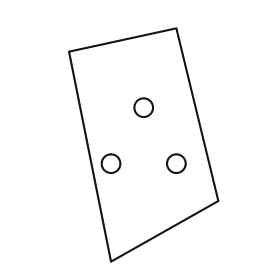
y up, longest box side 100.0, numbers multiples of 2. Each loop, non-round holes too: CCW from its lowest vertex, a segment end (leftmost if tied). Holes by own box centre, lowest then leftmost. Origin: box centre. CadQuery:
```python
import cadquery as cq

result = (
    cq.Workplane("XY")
    .moveTo(-14.0, -50.0)
    .lineTo(32.0, -24.0)
    .lineTo(14.0, 50.0)
    .lineTo(-32.0, 40.0)
    .close()
    .moveTo(-14.0, -8.0)
    .circle(4.0)
    .moveTo(14.0, -8.0)
    .circle(4.0)
    .moveTo(0.0, 16.0)
    .circle(4.0)
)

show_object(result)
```